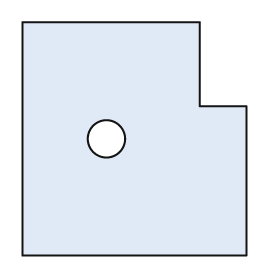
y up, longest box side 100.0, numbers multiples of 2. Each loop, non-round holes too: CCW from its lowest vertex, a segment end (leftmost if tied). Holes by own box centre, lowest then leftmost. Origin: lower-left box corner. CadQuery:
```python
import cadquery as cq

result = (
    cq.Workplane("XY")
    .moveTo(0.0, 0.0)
    .lineTo(96.0, 0.0)
    .lineTo(96.0, 64.0)
    .lineTo(76.0, 64.0)
    .lineTo(76.0, 100.0)
    .lineTo(0.0, 100.0)
    .close()
    .moveTo(36.0, 50.0)
    .circle(8.0)
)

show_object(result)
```